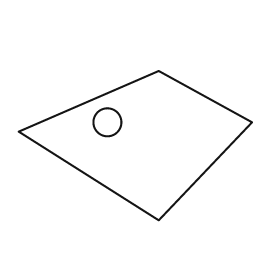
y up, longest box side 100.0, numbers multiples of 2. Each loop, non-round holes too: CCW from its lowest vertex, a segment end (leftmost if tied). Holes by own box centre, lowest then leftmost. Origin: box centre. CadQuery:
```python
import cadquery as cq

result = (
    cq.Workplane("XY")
    .moveTo(10.0, -32.0)
    .lineTo(50.0, 10.0)
    .lineTo(10.0, 32.0)
    .lineTo(-50.0, 6.0)
    .close()
    .moveTo(-12.0, 10.0)
    .circle(6.0)
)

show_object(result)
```